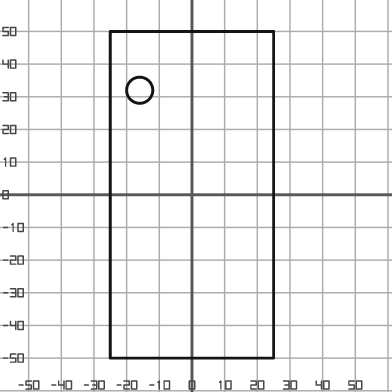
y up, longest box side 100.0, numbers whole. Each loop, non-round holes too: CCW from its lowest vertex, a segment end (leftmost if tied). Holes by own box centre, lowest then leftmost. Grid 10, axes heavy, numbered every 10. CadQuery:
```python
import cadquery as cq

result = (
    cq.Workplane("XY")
    .moveTo(-25.0, -50.0)
    .lineTo(25.0, -50.0)
    .lineTo(25.0, 50.0)
    .lineTo(-25.0, 50.0)
    .close()
    .moveTo(-16.0, 32.0)
    .circle(4.0)
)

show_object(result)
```